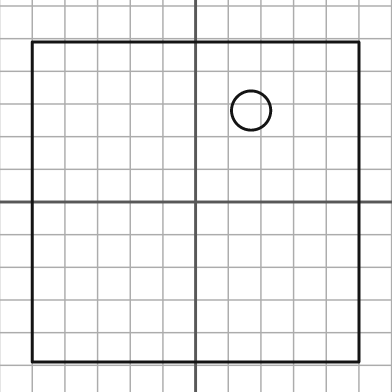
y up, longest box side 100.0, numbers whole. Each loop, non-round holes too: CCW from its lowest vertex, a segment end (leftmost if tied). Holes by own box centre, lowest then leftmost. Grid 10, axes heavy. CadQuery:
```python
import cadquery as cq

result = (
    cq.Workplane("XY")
    .moveTo(-50.0, -49.0)
    .lineTo(50.0, -49.0)
    .lineTo(50.0, 49.0)
    .lineTo(-50.0, 49.0)
    .close()
    .moveTo(17.0, 28.0)
    .circle(6.0)
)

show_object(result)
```